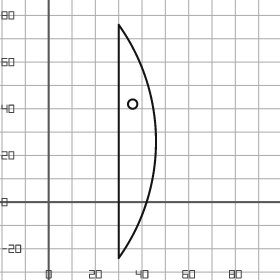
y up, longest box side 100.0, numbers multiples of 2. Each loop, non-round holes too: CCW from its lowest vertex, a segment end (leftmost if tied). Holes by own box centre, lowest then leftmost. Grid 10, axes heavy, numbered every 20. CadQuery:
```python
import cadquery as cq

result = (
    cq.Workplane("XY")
    .moveTo(30.0, -24.0)
    .threePointArc((46.0, 26.0), (30.0, 76.0))
    .close()
    .moveTo(36.0, 42.0)
    .circle(2.0)
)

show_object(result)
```